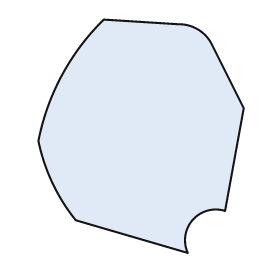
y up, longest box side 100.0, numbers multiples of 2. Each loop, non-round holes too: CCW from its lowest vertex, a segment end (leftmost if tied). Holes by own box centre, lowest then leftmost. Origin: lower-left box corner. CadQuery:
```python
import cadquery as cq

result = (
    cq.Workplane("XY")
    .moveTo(64.0, 0.0)
    .threePointArc((66.0, 14.0), (80.0, 18.0))
    .lineTo(88.0, 62.0)
    .lineTo(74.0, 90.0)
    .threePointArc((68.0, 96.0), (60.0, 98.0))
    .lineTo(28.0, 100.0)
    .threePointArc((10.0, 76.0), (0.0, 48.0))
    .threePointArc((6.0, 30.0), (16.0, 14.0))
    .close()
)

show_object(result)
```